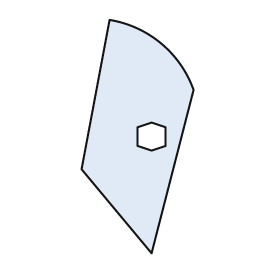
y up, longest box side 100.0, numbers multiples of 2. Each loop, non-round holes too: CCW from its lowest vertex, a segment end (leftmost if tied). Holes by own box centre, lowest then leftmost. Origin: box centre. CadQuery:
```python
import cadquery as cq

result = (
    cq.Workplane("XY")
    .moveTo(6.0, -50.0)
    .lineTo(24.0, 20.0)
    .threePointArc((10.0, 40.0), (-12.0, 50.0))
    .lineTo(-24.0, -14.0)
    .close()
    .moveTo(6.0, -6.0)
    .lineTo(12.0, -4.0)
    .lineTo(12.0, 4.0)
    .lineTo(6.0, 6.0)
    .lineTo(0.0, 4.0)
    .lineTo(0.0, -4.0)
    .close()
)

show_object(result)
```